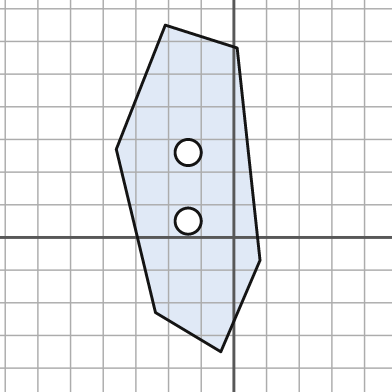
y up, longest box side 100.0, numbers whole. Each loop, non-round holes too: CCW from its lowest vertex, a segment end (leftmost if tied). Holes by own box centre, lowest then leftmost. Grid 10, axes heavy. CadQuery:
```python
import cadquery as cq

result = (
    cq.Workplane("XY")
    .moveTo(-4.0, -35.0)
    .lineTo(8.0, -7.0)
    .lineTo(1.0, 58.0)
    .lineTo(-21.0, 65.0)
    .lineTo(-36.0, 27.0)
    .lineTo(-24.0, -23.0)
    .close()
    .moveTo(-14.0, 5.0)
    .circle(4.0)
    .moveTo(-14.0, 26.0)
    .circle(4.0)
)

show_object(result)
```